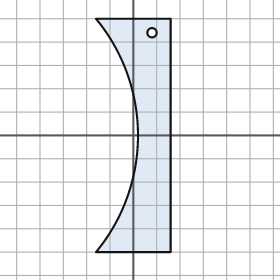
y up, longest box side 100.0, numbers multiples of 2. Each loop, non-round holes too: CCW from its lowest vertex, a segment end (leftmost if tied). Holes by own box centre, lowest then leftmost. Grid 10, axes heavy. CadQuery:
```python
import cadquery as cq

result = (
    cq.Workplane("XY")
    .moveTo(-16.0, -50.0)
    .lineTo(16.0, -50.0)
    .lineTo(16.0, 50.0)
    .lineTo(-16.0, 50.0)
    .threePointArc((2.0, 0.0), (-16.0, -50.0))
    .close()
    .moveTo(8.0, 44.0)
    .circle(2.0)
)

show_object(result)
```